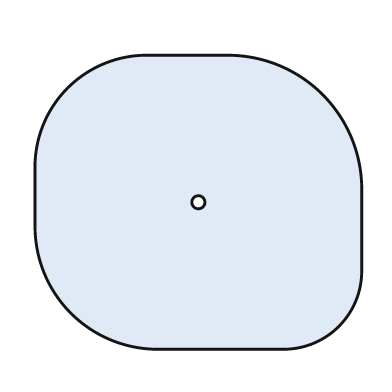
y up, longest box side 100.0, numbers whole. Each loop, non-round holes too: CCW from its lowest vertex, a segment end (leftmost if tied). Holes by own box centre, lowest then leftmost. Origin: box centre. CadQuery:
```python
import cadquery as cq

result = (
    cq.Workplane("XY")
    .moveTo(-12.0, -45.0)
    .lineTo(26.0, -45.0)
    .threePointArc((43.0, -38.0), (50.0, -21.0))
    .lineTo(50.0, 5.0)
    .threePointArc((38.0, 33.0), (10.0, 45.0))
    .lineTo(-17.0, 45.0)
    .threePointArc((-40.0, 35.0), (-50.0, 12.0))
    .lineTo(-50.0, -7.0)
    .threePointArc((-39.0, -34.0), (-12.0, -45.0))
    .close()
    .moveTo(0.0, 0.0)
    .circle(2.0)
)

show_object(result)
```